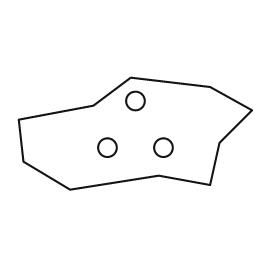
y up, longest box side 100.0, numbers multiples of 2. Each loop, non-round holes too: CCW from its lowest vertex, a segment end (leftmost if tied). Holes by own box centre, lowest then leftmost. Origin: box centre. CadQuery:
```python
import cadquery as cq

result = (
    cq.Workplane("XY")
    .moveTo(-28.0, -24.0)
    .lineTo(10.0, -18.0)
    .lineTo(32.0, -22.0)
    .lineTo(36.0, -4.0)
    .lineTo(50.0, 10.0)
    .lineTo(32.0, 20.0)
    .lineTo(-2.0, 24.0)
    .lineTo(-18.0, 12.0)
    .lineTo(-50.0, 6.0)
    .lineTo(-48.0, -12.0)
    .close()
    .moveTo(-12.0, -6.0)
    .circle(4.0)
    .moveTo(12.0, -6.0)
    .circle(4.0)
    .moveTo(0.0, 14.0)
    .circle(4.0)
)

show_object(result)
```